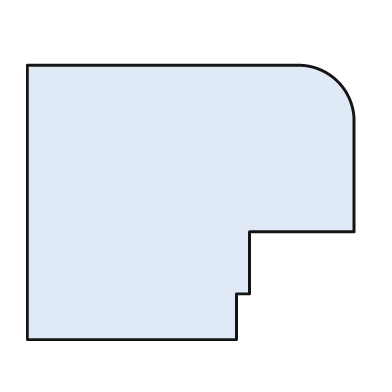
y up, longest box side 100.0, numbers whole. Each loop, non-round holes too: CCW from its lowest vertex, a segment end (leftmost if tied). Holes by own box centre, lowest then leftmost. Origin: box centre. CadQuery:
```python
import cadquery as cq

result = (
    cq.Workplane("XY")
    .moveTo(-50.0, -42.0)
    .lineTo(14.0, -42.0)
    .lineTo(14.0, -28.0)
    .lineTo(18.0, -28.0)
    .lineTo(18.0, -9.0)
    .lineTo(50.0, -9.0)
    .lineTo(50.0, 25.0)
    .threePointArc((45.0, 37.0), (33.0, 42.0))
    .lineTo(-50.0, 42.0)
    .close()
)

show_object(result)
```